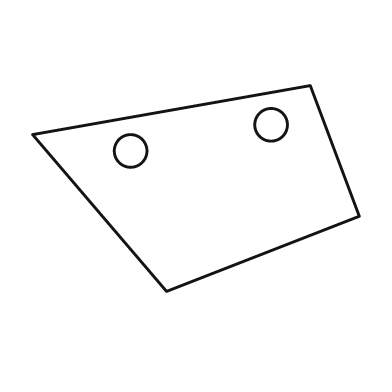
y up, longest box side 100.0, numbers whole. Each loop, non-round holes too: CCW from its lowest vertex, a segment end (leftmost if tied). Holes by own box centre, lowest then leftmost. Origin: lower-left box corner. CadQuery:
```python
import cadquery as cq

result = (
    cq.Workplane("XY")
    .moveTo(41.0, 0.0)
    .lineTo(100.0, 23.0)
    .lineTo(85.0, 63.0)
    .lineTo(0.0, 48.0)
    .close()
    .moveTo(30.0, 43.0)
    .circle(5.0)
    .moveTo(73.0, 51.0)
    .circle(5.0)
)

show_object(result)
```